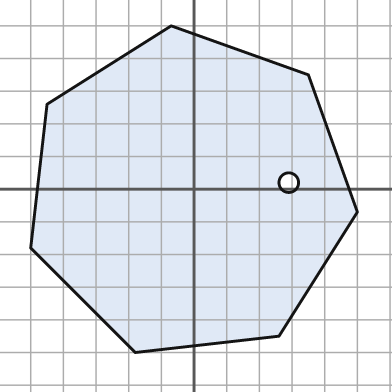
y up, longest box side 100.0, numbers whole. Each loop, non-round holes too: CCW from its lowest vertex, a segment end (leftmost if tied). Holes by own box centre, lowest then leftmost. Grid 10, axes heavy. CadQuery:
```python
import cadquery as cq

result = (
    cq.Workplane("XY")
    .moveTo(-18.0, -50.0)
    .lineTo(26.0, -45.0)
    .lineTo(50.0, -7.0)
    .lineTo(35.0, 35.0)
    .lineTo(-7.0, 50.0)
    .lineTo(-45.0, 26.0)
    .lineTo(-50.0, -18.0)
    .close()
    .moveTo(29.0, 2.0)
    .circle(3.0)
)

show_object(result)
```